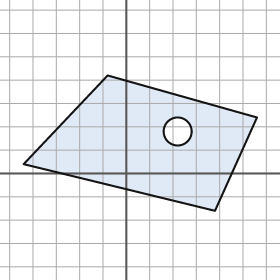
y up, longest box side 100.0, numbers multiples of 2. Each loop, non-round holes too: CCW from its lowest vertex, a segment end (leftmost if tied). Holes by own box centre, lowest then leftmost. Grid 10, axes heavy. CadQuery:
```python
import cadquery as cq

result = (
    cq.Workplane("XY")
    .moveTo(38.0, -16.0)
    .lineTo(56.0, 24.0)
    .lineTo(-8.0, 42.0)
    .lineTo(-44.0, 4.0)
    .close()
    .moveTo(22.0, 18.0)
    .circle(6.0)
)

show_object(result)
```